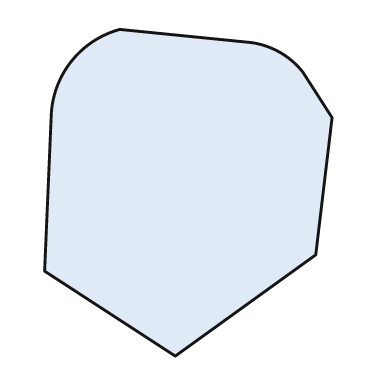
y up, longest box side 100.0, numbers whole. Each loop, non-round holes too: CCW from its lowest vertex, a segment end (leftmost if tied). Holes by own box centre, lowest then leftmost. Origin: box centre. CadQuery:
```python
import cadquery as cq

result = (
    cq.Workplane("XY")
    .moveTo(-4.0, -50.0)
    .lineTo(39.0, -19.0)
    .lineTo(44.0, 23.0)
    .lineTo(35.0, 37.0)
    .threePointArc((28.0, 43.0), (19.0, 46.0))
    .lineTo(-21.0, 50.0)
    .threePointArc((-36.0, 40.0), (-42.0, 23.0))
    .lineTo(-44.0, -24.0)
    .close()
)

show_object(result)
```